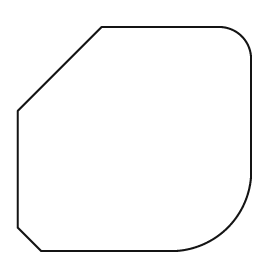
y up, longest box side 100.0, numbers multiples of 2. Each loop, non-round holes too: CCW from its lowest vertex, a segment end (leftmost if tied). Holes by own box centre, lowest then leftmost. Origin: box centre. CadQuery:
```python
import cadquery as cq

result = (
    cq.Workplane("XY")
    .moveTo(-40.0, -48.0)
    .lineTo(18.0, -48.0)
    .threePointArc((40.0, -38.0), (50.0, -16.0))
    .lineTo(50.0, 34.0)
    .threePointArc((46.0, 44.0), (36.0, 48.0))
    .lineTo(-14.0, 48.0)
    .lineTo(-50.0, 12.0)
    .lineTo(-50.0, -38.0)
    .close()
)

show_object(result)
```